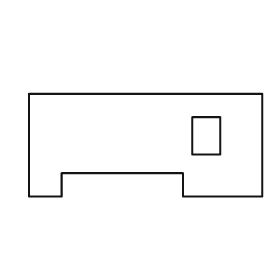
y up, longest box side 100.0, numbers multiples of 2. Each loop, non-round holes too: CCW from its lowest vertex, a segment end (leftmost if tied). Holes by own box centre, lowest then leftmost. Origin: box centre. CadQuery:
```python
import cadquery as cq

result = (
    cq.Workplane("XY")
    .moveTo(-50.0, -22.0)
    .lineTo(-36.0, -22.0)
    .lineTo(-36.0, -12.0)
    .lineTo(16.0, -12.0)
    .lineTo(16.0, -22.0)
    .lineTo(50.0, -22.0)
    .lineTo(50.0, 22.0)
    .lineTo(-50.0, 22.0)
    .close()
    .moveTo(20.0, -4.0)
    .lineTo(32.0, -4.0)
    .lineTo(32.0, 12.0)
    .lineTo(20.0, 12.0)
    .close()
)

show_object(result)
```